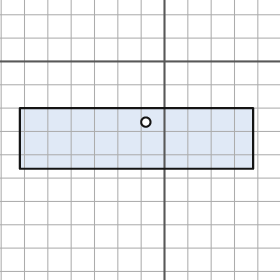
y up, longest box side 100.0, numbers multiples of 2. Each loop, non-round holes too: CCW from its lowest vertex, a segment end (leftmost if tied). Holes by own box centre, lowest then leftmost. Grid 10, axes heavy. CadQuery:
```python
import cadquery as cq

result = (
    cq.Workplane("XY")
    .moveTo(-62.0, -46.0)
    .lineTo(38.0, -46.0)
    .lineTo(38.0, -20.0)
    .lineTo(-62.0, -20.0)
    .close()
    .moveTo(-8.0, -26.0)
    .circle(2.0)
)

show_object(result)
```